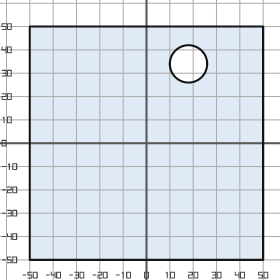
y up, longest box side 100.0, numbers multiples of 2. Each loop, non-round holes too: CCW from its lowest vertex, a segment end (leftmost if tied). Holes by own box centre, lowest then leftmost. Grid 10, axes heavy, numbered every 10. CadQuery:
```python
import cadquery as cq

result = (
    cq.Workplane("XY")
    .moveTo(-50.0, -50.0)
    .lineTo(50.0, -50.0)
    .lineTo(50.0, 50.0)
    .lineTo(-50.0, 50.0)
    .close()
    .moveTo(18.0, 34.0)
    .circle(8.0)
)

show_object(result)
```